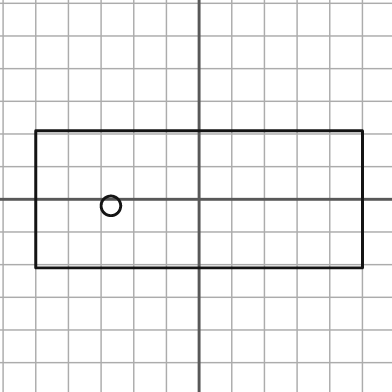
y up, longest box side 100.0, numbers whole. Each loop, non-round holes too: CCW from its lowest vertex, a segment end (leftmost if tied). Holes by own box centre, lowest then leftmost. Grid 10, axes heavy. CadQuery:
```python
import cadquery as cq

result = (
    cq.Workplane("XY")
    .moveTo(-50.0, -21.0)
    .lineTo(50.0, -21.0)
    .lineTo(50.0, 21.0)
    .lineTo(-50.0, 21.0)
    .close()
    .moveTo(-27.0, -2.0)
    .circle(3.0)
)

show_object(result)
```